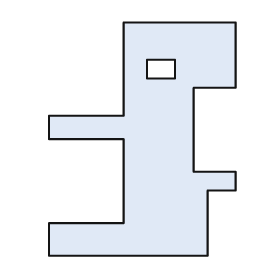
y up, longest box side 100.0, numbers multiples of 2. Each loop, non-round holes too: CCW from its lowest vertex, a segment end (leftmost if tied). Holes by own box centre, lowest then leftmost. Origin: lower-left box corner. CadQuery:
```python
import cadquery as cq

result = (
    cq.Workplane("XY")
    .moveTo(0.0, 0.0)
    .lineTo(68.0, 0.0)
    .lineTo(68.0, 28.0)
    .lineTo(80.0, 28.0)
    .lineTo(80.0, 36.0)
    .lineTo(62.0, 36.0)
    .lineTo(62.0, 72.0)
    .lineTo(80.0, 72.0)
    .lineTo(80.0, 100.0)
    .lineTo(32.0, 100.0)
    .lineTo(32.0, 60.0)
    .lineTo(0.0, 60.0)
    .lineTo(0.0, 50.0)
    .lineTo(32.0, 50.0)
    .lineTo(32.0, 14.0)
    .lineTo(0.0, 14.0)
    .close()
    .moveTo(42.0, 76.0)
    .lineTo(54.0, 76.0)
    .lineTo(54.0, 84.0)
    .lineTo(42.0, 84.0)
    .close()
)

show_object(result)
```